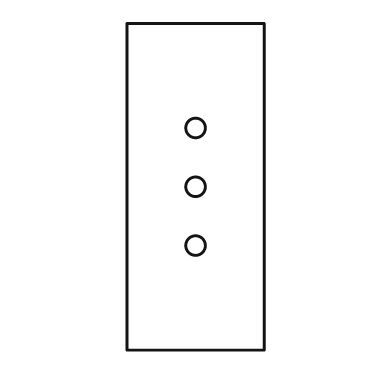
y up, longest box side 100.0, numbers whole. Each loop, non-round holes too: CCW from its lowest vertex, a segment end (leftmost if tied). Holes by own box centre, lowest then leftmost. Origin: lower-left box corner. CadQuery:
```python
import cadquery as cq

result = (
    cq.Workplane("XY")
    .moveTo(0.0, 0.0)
    .lineTo(42.0, 0.0)
    .lineTo(42.0, 100.0)
    .lineTo(0.0, 100.0)
    .close()
    .moveTo(21.0, 32.0)
    .circle(3.0)
    .moveTo(21.0, 50.0)
    .circle(3.0)
    .moveTo(21.0, 68.0)
    .circle(3.0)
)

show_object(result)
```